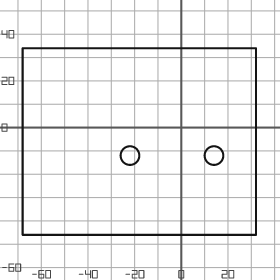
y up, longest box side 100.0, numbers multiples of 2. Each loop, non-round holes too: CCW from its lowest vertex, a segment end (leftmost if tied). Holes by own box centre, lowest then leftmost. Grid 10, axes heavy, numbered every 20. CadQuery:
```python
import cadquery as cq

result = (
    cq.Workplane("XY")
    .moveTo(-68.0, -46.0)
    .lineTo(32.0, -46.0)
    .lineTo(32.0, 34.0)
    .lineTo(-68.0, 34.0)
    .close()
    .moveTo(-22.0, -12.0)
    .circle(4.0)
    .moveTo(14.0, -12.0)
    .circle(4.0)
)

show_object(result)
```